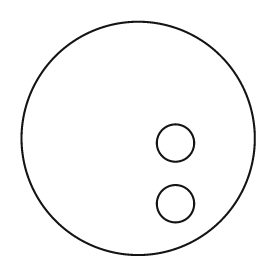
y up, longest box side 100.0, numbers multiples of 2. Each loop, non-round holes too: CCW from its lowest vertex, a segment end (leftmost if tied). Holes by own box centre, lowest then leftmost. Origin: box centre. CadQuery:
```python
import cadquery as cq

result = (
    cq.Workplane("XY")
    .moveTo(0.0, 0.0)
    .circle(50.0)
    .moveTo(16.0, -28.0)
    .circle(8.0)
    .moveTo(16.0, -2.0)
    .circle(8.0)
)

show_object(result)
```